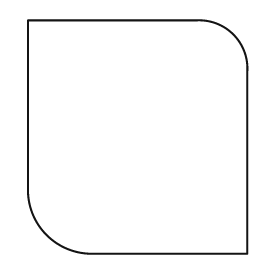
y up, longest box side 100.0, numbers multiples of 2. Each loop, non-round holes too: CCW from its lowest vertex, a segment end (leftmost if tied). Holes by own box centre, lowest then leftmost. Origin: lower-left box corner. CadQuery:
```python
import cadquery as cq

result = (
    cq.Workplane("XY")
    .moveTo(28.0, 0.0)
    .lineTo(94.0, 0.0)
    .lineTo(94.0, 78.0)
    .threePointArc((88.0, 94.0), (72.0, 100.0))
    .lineTo(0.0, 100.0)
    .lineTo(0.0, 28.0)
    .threePointArc((8.0, 8.0), (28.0, 0.0))
    .close()
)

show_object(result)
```